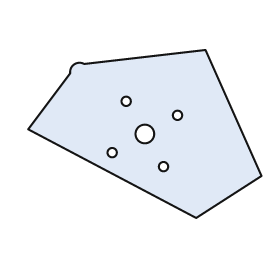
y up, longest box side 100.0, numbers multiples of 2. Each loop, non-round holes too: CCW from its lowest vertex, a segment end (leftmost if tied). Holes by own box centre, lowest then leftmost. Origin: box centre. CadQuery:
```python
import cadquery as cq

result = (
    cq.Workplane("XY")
    .moveTo(22.0, -36.0)
    .lineTo(50.0, -18.0)
    .lineTo(26.0, 36.0)
    .lineTo(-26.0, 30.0)
    .threePointArc((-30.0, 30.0), (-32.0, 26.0))
    .lineTo(-50.0, 2.0)
    .close()
    .moveTo(8.0, -14.0)
    .circle(2.0)
    .moveTo(-14.0, -8.0)
    .circle(2.0)
    .moveTo(0.0, 0.0)
    .circle(4.0)
    .moveTo(14.0, 8.0)
    .circle(2.0)
    .moveTo(-8.0, 14.0)
    .circle(2.0)
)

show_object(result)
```